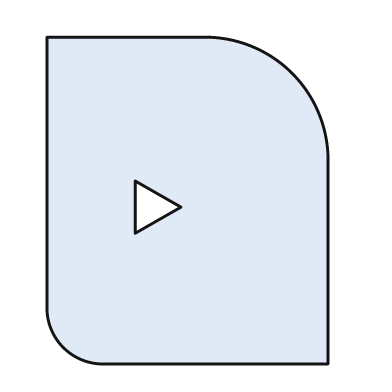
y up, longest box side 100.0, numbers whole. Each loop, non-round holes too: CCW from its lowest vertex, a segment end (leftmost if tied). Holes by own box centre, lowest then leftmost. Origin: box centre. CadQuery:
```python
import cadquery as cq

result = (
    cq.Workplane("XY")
    .moveTo(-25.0, -50.0)
    .lineTo(43.0, -50.0)
    .lineTo(43.0, 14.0)
    .threePointArc((32.0, 39.0), (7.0, 50.0))
    .lineTo(-43.0, 50.0)
    .lineTo(-43.0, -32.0)
    .threePointArc((-38.0, -45.0), (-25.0, -50.0))
    .close()
    .moveTo(-16.0, -10.0)
    .lineTo(-2.0, -2.0)
    .lineTo(-16.0, 6.0)
    .close()
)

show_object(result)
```